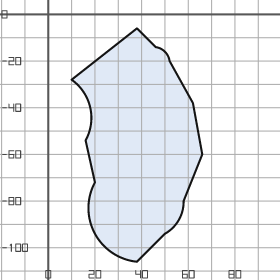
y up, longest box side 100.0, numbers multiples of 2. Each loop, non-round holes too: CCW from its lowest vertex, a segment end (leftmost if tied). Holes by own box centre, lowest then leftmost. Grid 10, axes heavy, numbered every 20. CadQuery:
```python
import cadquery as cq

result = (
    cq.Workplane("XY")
    .moveTo(38.0, -106.0)
    .lineTo(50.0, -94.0)
    .threePointArc((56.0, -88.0), (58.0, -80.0))
    .lineTo(66.0, -60.0)
    .lineTo(62.0, -38.0)
    .lineTo(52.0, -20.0)
    .threePointArc((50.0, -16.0), (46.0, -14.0))
    .lineTo(38.0, -6.0)
    .lineTo(10.0, -28.0)
    .threePointArc((18.0, -40.0), (16.0, -54.0))
    .lineTo(20.0, -72.0)
    .threePointArc((20.0, -94.0), (38.0, -106.0))
    .close()
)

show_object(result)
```